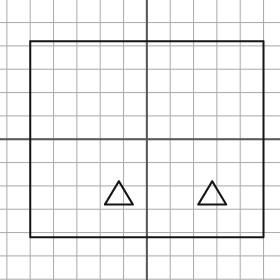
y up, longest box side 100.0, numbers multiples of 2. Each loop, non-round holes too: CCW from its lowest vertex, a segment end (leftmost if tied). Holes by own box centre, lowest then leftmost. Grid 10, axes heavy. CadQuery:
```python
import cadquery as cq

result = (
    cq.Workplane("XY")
    .moveTo(-50.0, -42.0)
    .lineTo(50.0, -42.0)
    .lineTo(50.0, 42.0)
    .lineTo(-50.0, 42.0)
    .close()
    .moveTo(-18.0, -28.0)
    .lineTo(-6.0, -28.0)
    .lineTo(-12.0, -18.0)
    .close()
    .moveTo(22.0, -28.0)
    .lineTo(34.0, -28.0)
    .lineTo(28.0, -18.0)
    .close()
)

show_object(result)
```